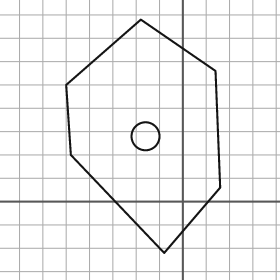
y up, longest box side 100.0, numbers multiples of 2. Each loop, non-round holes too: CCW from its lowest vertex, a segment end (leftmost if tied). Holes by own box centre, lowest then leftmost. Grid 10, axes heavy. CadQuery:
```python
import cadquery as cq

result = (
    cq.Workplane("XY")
    .moveTo(-8.0, -22.0)
    .lineTo(16.0, 6.0)
    .lineTo(14.0, 56.0)
    .lineTo(-18.0, 78.0)
    .lineTo(-50.0, 50.0)
    .lineTo(-48.0, 20.0)
    .close()
    .moveTo(-16.0, 28.0)
    .circle(6.0)
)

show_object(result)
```